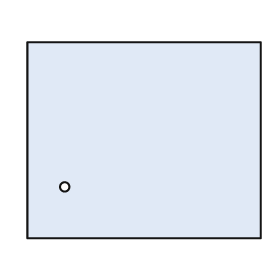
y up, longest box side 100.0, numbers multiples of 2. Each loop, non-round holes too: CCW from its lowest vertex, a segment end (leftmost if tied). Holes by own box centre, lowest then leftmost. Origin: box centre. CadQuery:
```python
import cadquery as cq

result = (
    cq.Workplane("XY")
    .moveTo(-50.0, -42.0)
    .lineTo(50.0, -42.0)
    .lineTo(50.0, 42.0)
    .lineTo(-50.0, 42.0)
    .close()
    .moveTo(-34.0, -20.0)
    .circle(2.0)
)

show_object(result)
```